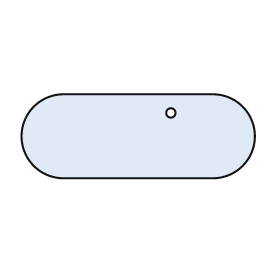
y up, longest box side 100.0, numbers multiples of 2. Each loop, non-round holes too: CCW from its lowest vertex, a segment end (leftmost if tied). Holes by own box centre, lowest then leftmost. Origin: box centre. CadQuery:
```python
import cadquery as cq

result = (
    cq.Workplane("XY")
    .moveTo(-32.0, -18.0)
    .lineTo(32.0, -18.0)
    .threePointArc((50.0, 0.0), (32.0, 18.0))
    .lineTo(-32.0, 18.0)
    .threePointArc((-50.0, 0.0), (-32.0, -18.0))
    .close()
    .moveTo(14.0, 10.0)
    .circle(2.0)
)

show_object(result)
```